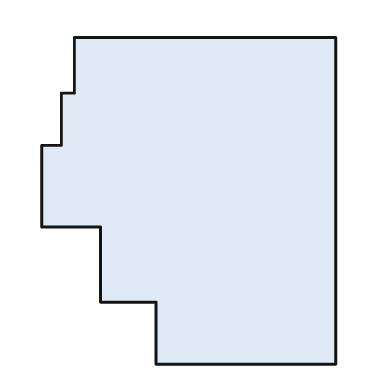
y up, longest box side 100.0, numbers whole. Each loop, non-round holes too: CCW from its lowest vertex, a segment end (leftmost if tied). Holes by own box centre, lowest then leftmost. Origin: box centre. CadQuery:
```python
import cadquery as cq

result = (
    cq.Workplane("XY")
    .moveTo(-10.0, -50.0)
    .lineTo(45.0, -50.0)
    .lineTo(45.0, 50.0)
    .lineTo(-35.0, 50.0)
    .lineTo(-35.0, 33.0)
    .lineTo(-39.0, 33.0)
    .lineTo(-39.0, 17.0)
    .lineTo(-45.0, 17.0)
    .lineTo(-45.0, -8.0)
    .lineTo(-27.0, -8.0)
    .lineTo(-27.0, -31.0)
    .lineTo(-10.0, -31.0)
    .close()
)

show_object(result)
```